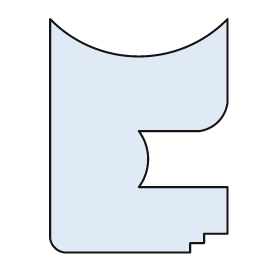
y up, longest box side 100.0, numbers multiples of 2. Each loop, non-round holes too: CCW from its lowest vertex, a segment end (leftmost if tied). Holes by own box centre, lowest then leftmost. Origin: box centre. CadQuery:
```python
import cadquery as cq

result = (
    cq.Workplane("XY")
    .moveTo(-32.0, -50.0)
    .lineTo(22.0, -50.0)
    .lineTo(22.0, -46.0)
    .lineTo(28.0, -46.0)
    .lineTo(28.0, -42.0)
    .lineTo(38.0, -42.0)
    .lineTo(38.0, -22.0)
    .lineTo(0.0, -22.0)
    .threePointArc((4.0, -10.0), (0.0, 2.0))
    .lineTo(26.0, 2.0)
    .threePointArc((34.0, 6.0), (38.0, 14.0))
    .lineTo(38.0, 50.0)
    .threePointArc((0.0, 34.0), (-38.0, 50.0))
    .lineTo(-38.0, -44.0)
    .threePointArc((-36.0, -48.0), (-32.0, -50.0))
    .close()
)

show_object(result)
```